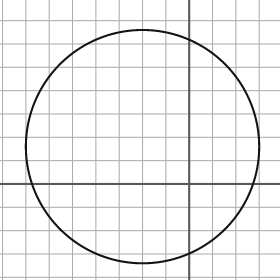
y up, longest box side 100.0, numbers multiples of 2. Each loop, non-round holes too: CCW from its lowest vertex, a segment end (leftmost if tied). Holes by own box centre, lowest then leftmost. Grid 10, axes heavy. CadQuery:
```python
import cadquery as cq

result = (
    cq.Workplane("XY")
    .moveTo(-20.0, 16.0)
    .circle(50.0)
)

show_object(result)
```